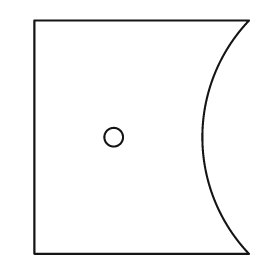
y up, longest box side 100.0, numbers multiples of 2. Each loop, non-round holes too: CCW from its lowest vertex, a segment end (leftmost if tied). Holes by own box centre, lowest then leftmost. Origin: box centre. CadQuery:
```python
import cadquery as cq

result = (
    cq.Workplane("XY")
    .moveTo(-46.0, -50.0)
    .lineTo(46.0, -50.0)
    .threePointArc((26.0, 0.0), (46.0, 50.0))
    .lineTo(-46.0, 50.0)
    .close()
    .moveTo(-12.0, 0.0)
    .circle(4.0)
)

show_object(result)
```